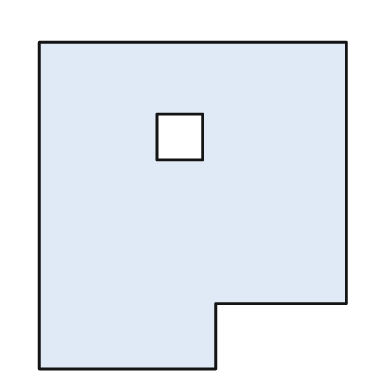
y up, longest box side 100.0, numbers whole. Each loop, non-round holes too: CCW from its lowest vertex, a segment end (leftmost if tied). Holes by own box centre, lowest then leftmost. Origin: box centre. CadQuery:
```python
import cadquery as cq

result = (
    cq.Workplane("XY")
    .moveTo(-47.0, -50.0)
    .lineTo(7.0, -50.0)
    .lineTo(7.0, -30.0)
    .lineTo(47.0, -30.0)
    .lineTo(47.0, 50.0)
    .lineTo(-47.0, 50.0)
    .close()
    .moveTo(-11.0, 14.0)
    .lineTo(3.0, 14.0)
    .lineTo(3.0, 28.0)
    .lineTo(-11.0, 28.0)
    .close()
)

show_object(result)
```